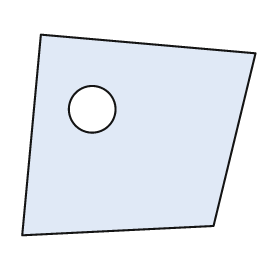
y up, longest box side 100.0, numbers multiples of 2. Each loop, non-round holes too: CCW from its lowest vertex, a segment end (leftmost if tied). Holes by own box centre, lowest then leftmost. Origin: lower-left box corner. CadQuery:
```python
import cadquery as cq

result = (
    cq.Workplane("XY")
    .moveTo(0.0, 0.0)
    .lineTo(82.0, 4.0)
    .lineTo(100.0, 78.0)
    .lineTo(8.0, 86.0)
    .close()
    .moveTo(30.0, 54.0)
    .circle(10.0)
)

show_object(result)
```